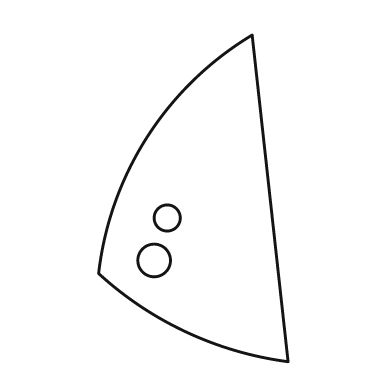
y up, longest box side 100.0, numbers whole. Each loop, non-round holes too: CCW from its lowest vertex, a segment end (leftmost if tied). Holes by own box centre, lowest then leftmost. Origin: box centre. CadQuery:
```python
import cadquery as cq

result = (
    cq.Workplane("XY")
    .moveTo(29.0, -50.0)
    .lineTo(18.0, 50.0)
    .threePointArc((-14.0, 19.0), (-29.0, -23.0))
    .threePointArc((-2.0, -41.0), (29.0, -50.0))
    .close()
    .moveTo(-12.0, -19.0)
    .circle(5.0)
    .moveTo(-8.0, -6.0)
    .circle(4.0)
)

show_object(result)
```